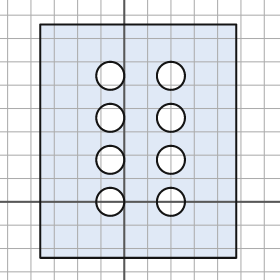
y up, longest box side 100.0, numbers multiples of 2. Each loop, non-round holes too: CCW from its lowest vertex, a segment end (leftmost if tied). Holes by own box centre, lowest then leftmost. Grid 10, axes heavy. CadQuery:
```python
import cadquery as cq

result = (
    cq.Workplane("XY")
    .moveTo(-36.0, -24.0)
    .lineTo(48.0, -24.0)
    .lineTo(48.0, 76.0)
    .lineTo(-36.0, 76.0)
    .close()
    .moveTo(-6.0, 0.0)
    .circle(6.0)
    .moveTo(20.0, 0.0)
    .circle(6.0)
    .moveTo(-6.0, 18.0)
    .circle(6.0)
    .moveTo(20.0, 18.0)
    .circle(6.0)
    .moveTo(-6.0, 36.0)
    .circle(6.0)
    .moveTo(20.0, 36.0)
    .circle(6.0)
    .moveTo(-6.0, 54.0)
    .circle(6.0)
    .moveTo(20.0, 54.0)
    .circle(6.0)
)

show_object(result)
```